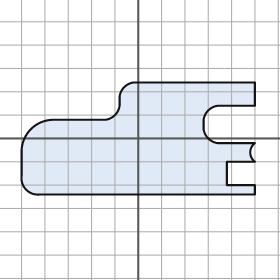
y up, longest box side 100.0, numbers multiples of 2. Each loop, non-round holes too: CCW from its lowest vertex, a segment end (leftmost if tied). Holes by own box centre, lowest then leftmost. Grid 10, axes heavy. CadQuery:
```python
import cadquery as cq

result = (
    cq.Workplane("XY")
    .moveTo(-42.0, -24.0)
    .lineTo(50.0, -24.0)
    .lineTo(50.0, -20.0)
    .lineTo(38.0, -20.0)
    .lineTo(38.0, -10.0)
    .lineTo(50.0, -10.0)
    .threePointArc((48.0, -6.0), (50.0, -2.0))
    .lineTo(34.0, -2.0)
    .threePointArc((30.0, 0.0), (28.0, 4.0))
    .lineTo(28.0, 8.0)
    .threePointArc((30.0, 12.0), (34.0, 14.0))
    .lineTo(50.0, 14.0)
    .lineTo(50.0, 24.0)
    .lineTo(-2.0, 24.0)
    .threePointArc((-6.0, 22.0), (-8.0, 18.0))
    .lineTo(-8.0, 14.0)
    .threePointArc((-10.0, 10.0), (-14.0, 8.0))
    .lineTo(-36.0, 8.0)
    .threePointArc((-46.0, 4.0), (-50.0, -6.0))
    .lineTo(-50.0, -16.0)
    .threePointArc((-48.0, -22.0), (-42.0, -24.0))
    .close()
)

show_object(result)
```